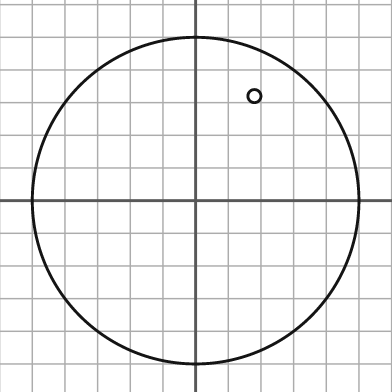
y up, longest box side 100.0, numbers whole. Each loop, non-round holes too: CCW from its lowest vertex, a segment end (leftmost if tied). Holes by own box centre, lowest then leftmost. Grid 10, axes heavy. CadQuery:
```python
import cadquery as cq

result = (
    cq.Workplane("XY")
    .moveTo(0.0, 0.0)
    .circle(50.0)
    .moveTo(18.0, 32.0)
    .circle(2.0)
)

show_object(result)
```